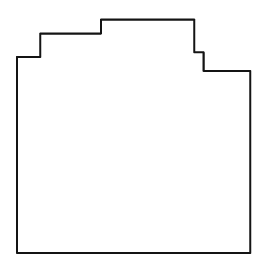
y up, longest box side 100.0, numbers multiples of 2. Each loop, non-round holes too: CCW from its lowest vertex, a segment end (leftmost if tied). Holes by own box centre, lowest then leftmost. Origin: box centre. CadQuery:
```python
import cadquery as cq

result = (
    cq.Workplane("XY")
    .moveTo(-50.0, -50.0)
    .lineTo(50.0, -50.0)
    .lineTo(50.0, 28.0)
    .lineTo(30.0, 28.0)
    .lineTo(30.0, 36.0)
    .lineTo(26.0, 36.0)
    .lineTo(26.0, 50.0)
    .lineTo(-14.0, 50.0)
    .lineTo(-14.0, 44.0)
    .lineTo(-40.0, 44.0)
    .lineTo(-40.0, 34.0)
    .lineTo(-50.0, 34.0)
    .close()
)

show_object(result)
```